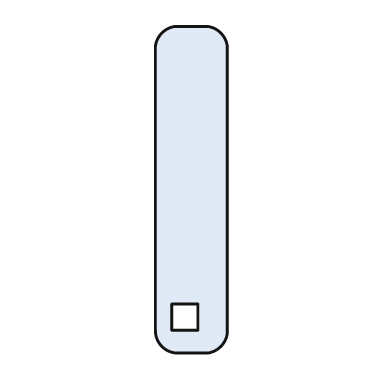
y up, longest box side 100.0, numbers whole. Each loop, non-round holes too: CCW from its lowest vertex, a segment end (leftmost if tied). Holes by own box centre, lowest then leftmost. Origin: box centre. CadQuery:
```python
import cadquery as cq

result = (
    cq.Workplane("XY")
    .moveTo(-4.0, -50.0)
    .lineTo(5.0, -50.0)
    .threePointArc((9.0, -48.0), (11.0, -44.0))
    .lineTo(11.0, 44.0)
    .threePointArc((9.0, 48.0), (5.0, 50.0))
    .lineTo(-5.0, 50.0)
    .threePointArc((-9.0, 48.0), (-11.0, 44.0))
    .lineTo(-11.0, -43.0)
    .threePointArc((-9.0, -48.0), (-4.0, -50.0))
    .close()
    .moveTo(-6.0, -43.0)
    .lineTo(2.0, -43.0)
    .lineTo(2.0, -35.0)
    .lineTo(-6.0, -35.0)
    .close()
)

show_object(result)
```